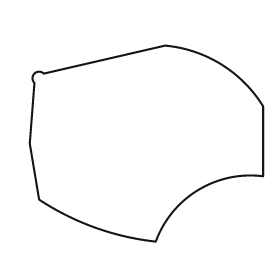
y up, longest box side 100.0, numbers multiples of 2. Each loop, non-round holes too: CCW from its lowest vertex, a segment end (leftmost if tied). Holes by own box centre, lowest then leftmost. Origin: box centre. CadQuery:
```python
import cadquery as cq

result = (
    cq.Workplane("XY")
    .moveTo(4.0, -42.0)
    .threePointArc((22.0, -20.0), (50.0, -14.0))
    .lineTo(50.0, 16.0)
    .threePointArc((32.0, 34.0), (8.0, 42.0))
    .lineTo(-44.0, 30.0)
    .threePointArc((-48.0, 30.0), (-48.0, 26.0))
    .lineTo(-50.0, 0.0)
    .lineTo(-46.0, -24.0)
    .threePointArc((-22.0, -36.0), (4.0, -42.0))
    .close()
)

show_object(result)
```